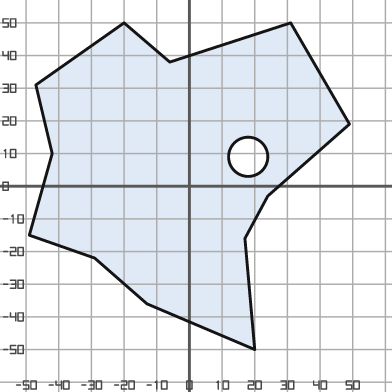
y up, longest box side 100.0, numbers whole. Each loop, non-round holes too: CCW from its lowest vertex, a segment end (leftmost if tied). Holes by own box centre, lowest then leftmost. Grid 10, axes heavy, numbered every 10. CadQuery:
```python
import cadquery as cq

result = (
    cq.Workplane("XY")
    .moveTo(20.0, -50.0)
    .lineTo(17.0, -16.0)
    .lineTo(24.0, -3.0)
    .lineTo(49.0, 19.0)
    .lineTo(31.0, 50.0)
    .lineTo(-6.0, 38.0)
    .lineTo(-20.0, 50.0)
    .lineTo(-47.0, 31.0)
    .lineTo(-42.0, 10.0)
    .lineTo(-49.0, -15.0)
    .lineTo(-29.0, -22.0)
    .lineTo(-13.0, -36.0)
    .close()
    .moveTo(18.0, 9.0)
    .circle(6.0)
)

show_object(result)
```